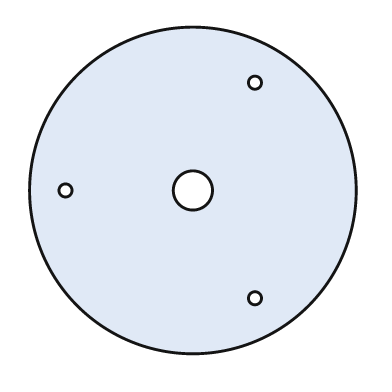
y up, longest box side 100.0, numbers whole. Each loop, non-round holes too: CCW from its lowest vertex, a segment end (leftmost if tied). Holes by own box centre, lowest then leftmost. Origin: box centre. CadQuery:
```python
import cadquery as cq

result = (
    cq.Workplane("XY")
    .moveTo(0.0, 0.0)
    .circle(50.0)
    .moveTo(19.0, -33.0)
    .circle(2.0)
    .moveTo(-39.0, 0.0)
    .circle(2.0)
    .moveTo(0.0, 0.0)
    .circle(6.0)
    .moveTo(19.0, 33.0)
    .circle(2.0)
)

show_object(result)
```